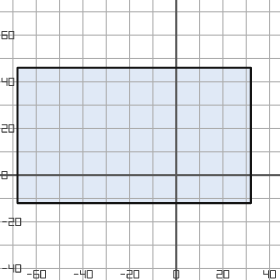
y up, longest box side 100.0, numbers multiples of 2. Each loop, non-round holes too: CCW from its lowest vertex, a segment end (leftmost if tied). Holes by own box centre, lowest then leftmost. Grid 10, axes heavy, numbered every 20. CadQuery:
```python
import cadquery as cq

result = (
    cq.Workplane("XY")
    .moveTo(-68.0, -12.0)
    .lineTo(32.0, -12.0)
    .lineTo(32.0, 46.0)
    .lineTo(-68.0, 46.0)
    .close()
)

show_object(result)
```